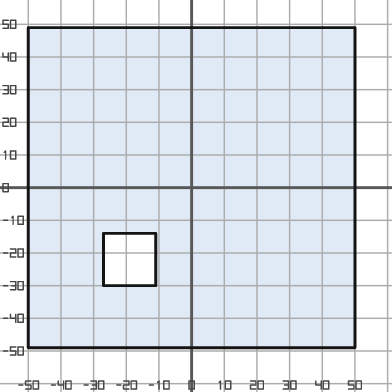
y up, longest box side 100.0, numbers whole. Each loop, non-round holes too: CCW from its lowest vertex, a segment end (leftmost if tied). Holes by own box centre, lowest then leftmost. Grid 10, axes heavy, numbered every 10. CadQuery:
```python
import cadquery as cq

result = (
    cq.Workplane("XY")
    .moveTo(-50.0, -49.0)
    .lineTo(50.0, -49.0)
    .lineTo(50.0, 49.0)
    .lineTo(-50.0, 49.0)
    .close()
    .moveTo(-27.0, -30.0)
    .lineTo(-11.0, -30.0)
    .lineTo(-11.0, -14.0)
    .lineTo(-27.0, -14.0)
    .close()
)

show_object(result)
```